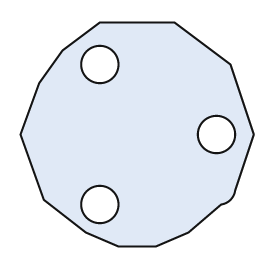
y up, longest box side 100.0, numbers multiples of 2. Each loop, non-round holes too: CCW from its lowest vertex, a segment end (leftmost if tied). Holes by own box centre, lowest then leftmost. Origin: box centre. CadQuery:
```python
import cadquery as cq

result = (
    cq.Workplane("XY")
    .moveTo(-8.0, -48.0)
    .lineTo(8.0, -48.0)
    .lineTo(22.0, -42.0)
    .lineTo(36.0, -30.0)
    .threePointArc((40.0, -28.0), (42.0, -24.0))
    .lineTo(50.0, 0.0)
    .lineTo(40.0, 30.0)
    .lineTo(16.0, 48.0)
    .lineTo(-16.0, 48.0)
    .lineTo(-32.0, 36.0)
    .lineTo(-42.0, 22.0)
    .lineTo(-50.0, 0.0)
    .lineTo(-40.0, -28.0)
    .lineTo(-22.0, -42.0)
    .close()
    .moveTo(-16.0, -30.0)
    .circle(8.0)
    .moveTo(34.0, 0.0)
    .circle(8.0)
    .moveTo(-16.0, 30.0)
    .circle(8.0)
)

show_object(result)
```